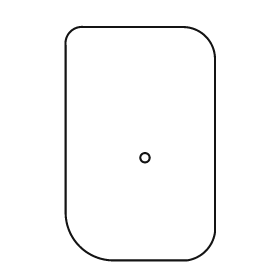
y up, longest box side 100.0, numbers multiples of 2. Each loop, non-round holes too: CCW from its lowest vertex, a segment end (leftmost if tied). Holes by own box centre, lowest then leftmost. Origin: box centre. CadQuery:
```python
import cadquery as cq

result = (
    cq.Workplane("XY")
    .moveTo(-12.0, -50.0)
    .lineTo(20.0, -50.0)
    .threePointArc((28.0, -46.0), (32.0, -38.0))
    .lineTo(32.0, 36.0)
    .threePointArc((28.0, 46.0), (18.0, 50.0))
    .lineTo(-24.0, 50.0)
    .threePointArc((-30.0, 48.0), (-32.0, 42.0))
    .lineTo(-32.0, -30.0)
    .threePointArc((-26.0, -44.0), (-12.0, -50.0))
    .close()
    .moveTo(2.0, -6.0)
    .circle(2.0)
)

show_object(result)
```